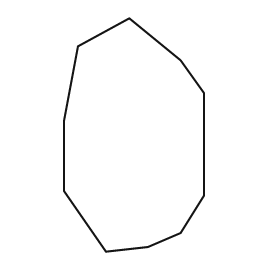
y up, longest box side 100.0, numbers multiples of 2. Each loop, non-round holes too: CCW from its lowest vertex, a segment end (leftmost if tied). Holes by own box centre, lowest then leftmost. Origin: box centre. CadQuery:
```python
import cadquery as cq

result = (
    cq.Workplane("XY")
    .moveTo(-12.0, -50.0)
    .lineTo(6.0, -48.0)
    .lineTo(20.0, -42.0)
    .lineTo(30.0, -26.0)
    .lineTo(30.0, 18.0)
    .lineTo(20.0, 32.0)
    .lineTo(-2.0, 50.0)
    .lineTo(-24.0, 38.0)
    .lineTo(-30.0, 6.0)
    .lineTo(-30.0, -24.0)
    .close()
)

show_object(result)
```